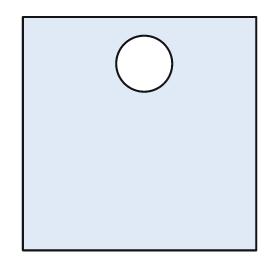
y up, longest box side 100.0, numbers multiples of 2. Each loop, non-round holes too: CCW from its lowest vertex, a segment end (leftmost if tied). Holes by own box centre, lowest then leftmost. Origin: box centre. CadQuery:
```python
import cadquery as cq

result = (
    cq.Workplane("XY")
    .moveTo(-50.0, -50.0)
    .lineTo(50.0, -50.0)
    .lineTo(50.0, 50.0)
    .lineTo(-50.0, 50.0)
    .close()
    .moveTo(2.0, 30.0)
    .circle(12.0)
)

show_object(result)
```